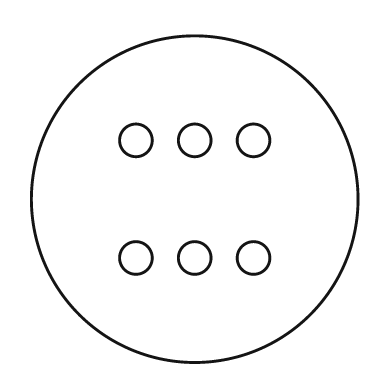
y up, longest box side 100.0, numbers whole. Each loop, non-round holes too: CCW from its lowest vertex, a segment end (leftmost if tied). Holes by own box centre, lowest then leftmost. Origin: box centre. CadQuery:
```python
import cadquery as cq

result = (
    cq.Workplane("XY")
    .moveTo(0.0, 0.0)
    .circle(50.0)
    .moveTo(-18.0, -18.0)
    .circle(5.0)
    .moveTo(0.0, -18.0)
    .circle(5.0)
    .moveTo(18.0, -18.0)
    .circle(5.0)
    .moveTo(-18.0, 18.0)
    .circle(5.0)
    .moveTo(0.0, 18.0)
    .circle(5.0)
    .moveTo(18.0, 18.0)
    .circle(5.0)
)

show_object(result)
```